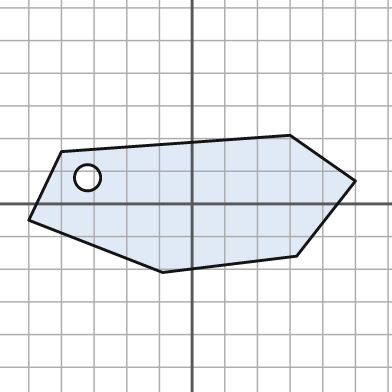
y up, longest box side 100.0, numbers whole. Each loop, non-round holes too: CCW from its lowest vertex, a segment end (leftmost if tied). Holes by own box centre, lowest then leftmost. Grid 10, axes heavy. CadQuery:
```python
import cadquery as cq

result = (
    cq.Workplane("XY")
    .moveTo(-9.0, -21.0)
    .lineTo(32.0, -16.0)
    .lineTo(50.0, 7.0)
    .lineTo(30.0, 21.0)
    .lineTo(-40.0, 16.0)
    .lineTo(-50.0, -5.0)
    .close()
    .moveTo(-32.0, 8.0)
    .circle(4.0)
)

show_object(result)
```